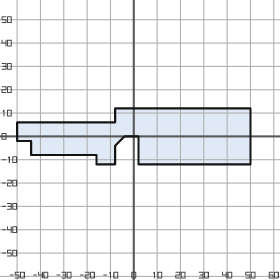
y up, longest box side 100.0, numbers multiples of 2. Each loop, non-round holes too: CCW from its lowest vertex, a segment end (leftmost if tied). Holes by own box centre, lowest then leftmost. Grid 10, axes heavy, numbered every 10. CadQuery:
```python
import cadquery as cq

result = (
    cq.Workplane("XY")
    .moveTo(-16.0, -12.0)
    .lineTo(-8.0, -12.0)
    .lineTo(-8.0, -4.0)
    .lineTo(-4.0, 0.0)
    .lineTo(2.0, 0.0)
    .lineTo(2.0, -12.0)
    .lineTo(50.0, -12.0)
    .lineTo(50.0, 12.0)
    .lineTo(-8.0, 12.0)
    .lineTo(-8.0, 6.0)
    .lineTo(-50.0, 6.0)
    .lineTo(-50.0, -2.0)
    .lineTo(-44.0, -2.0)
    .lineTo(-44.0, -8.0)
    .lineTo(-16.0, -8.0)
    .close()
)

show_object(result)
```